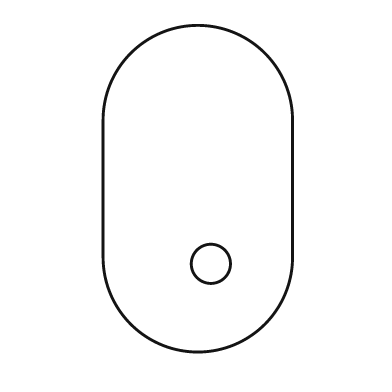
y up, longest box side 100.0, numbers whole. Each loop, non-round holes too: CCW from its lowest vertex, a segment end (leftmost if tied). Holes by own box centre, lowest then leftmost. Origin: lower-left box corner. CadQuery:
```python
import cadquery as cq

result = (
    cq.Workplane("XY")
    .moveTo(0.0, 29.0)
    .threePointArc((29.0, 0.0), (58.0, 29.0))
    .lineTo(58.0, 71.0)
    .threePointArc((29.0, 100.0), (0.0, 71.0))
    .close()
    .moveTo(33.0, 27.0)
    .circle(6.0)
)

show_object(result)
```